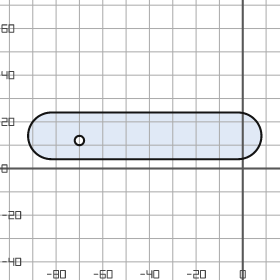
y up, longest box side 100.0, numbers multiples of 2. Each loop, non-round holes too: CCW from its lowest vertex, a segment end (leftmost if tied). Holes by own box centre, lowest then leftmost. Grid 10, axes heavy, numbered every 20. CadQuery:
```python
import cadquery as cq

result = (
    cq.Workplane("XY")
    .moveTo(-82.0, 4.0)
    .lineTo(-2.0, 4.0)
    .threePointArc((8.0, 14.0), (-2.0, 24.0))
    .lineTo(-82.0, 24.0)
    .threePointArc((-92.0, 14.0), (-82.0, 4.0))
    .close()
    .moveTo(-70.0, 12.0)
    .circle(2.0)
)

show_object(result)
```